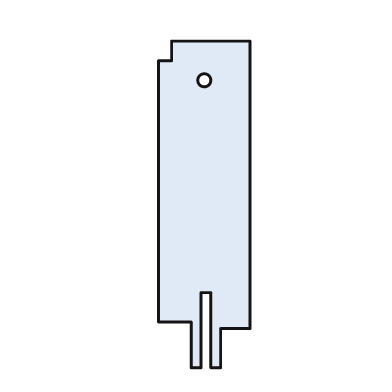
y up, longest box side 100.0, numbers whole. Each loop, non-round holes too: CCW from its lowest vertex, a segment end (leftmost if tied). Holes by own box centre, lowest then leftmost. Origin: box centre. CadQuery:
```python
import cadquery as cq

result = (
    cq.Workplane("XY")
    .moveTo(-4.0, -50.0)
    .lineTo(-1.0, -50.0)
    .lineTo(-1.0, -27.0)
    .lineTo(2.0, -27.0)
    .lineTo(2.0, -50.0)
    .lineTo(5.0, -50.0)
    .lineTo(5.0, -38.0)
    .lineTo(14.0, -38.0)
    .lineTo(14.0, 50.0)
    .lineTo(-10.0, 50.0)
    .lineTo(-10.0, 44.0)
    .lineTo(-14.0, 44.0)
    .lineTo(-14.0, -36.0)
    .lineTo(-4.0, -36.0)
    .close()
    .moveTo(0.0, 38.0)
    .circle(2.0)
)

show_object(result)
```